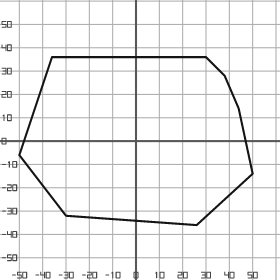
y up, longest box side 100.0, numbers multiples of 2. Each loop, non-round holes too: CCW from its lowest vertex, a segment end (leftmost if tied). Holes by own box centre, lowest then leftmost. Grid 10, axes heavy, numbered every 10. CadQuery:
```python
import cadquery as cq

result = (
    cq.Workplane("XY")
    .moveTo(26.0, -36.0)
    .lineTo(50.0, -14.0)
    .lineTo(44.0, 14.0)
    .lineTo(38.0, 28.0)
    .lineTo(30.0, 36.0)
    .lineTo(-36.0, 36.0)
    .lineTo(-50.0, -6.0)
    .lineTo(-30.0, -32.0)
    .close()
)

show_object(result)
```